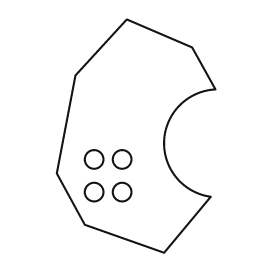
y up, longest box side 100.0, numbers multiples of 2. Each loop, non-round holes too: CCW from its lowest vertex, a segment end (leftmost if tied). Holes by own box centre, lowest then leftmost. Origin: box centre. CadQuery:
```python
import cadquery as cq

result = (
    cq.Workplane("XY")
    .moveTo(12.0, -50.0)
    .lineTo(32.0, -26.0)
    .threePointArc((12.0, -2.0), (34.0, 20.0))
    .lineTo(24.0, 38.0)
    .lineTo(-4.0, 50.0)
    .lineTo(-26.0, 26.0)
    .lineTo(-34.0, -16.0)
    .lineTo(-22.0, -38.0)
    .close()
    .moveTo(-18.0, -24.0)
    .circle(4.0)
    .moveTo(-6.0, -24.0)
    .circle(4.0)
    .moveTo(-18.0, -10.0)
    .circle(4.0)
    .moveTo(-6.0, -10.0)
    .circle(4.0)
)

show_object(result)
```